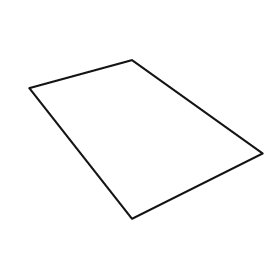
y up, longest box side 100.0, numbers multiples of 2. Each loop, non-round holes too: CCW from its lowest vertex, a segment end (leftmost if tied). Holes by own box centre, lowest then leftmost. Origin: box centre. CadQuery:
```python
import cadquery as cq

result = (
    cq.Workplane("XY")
    .moveTo(-6.0, -34.0)
    .lineTo(50.0, -6.0)
    .lineTo(-6.0, 34.0)
    .lineTo(-50.0, 22.0)
    .close()
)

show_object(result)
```